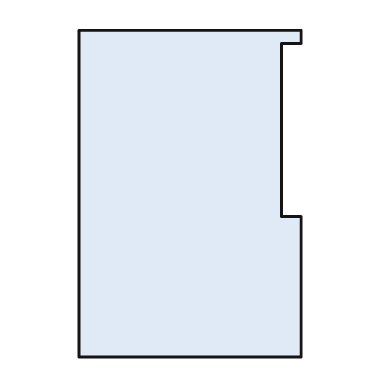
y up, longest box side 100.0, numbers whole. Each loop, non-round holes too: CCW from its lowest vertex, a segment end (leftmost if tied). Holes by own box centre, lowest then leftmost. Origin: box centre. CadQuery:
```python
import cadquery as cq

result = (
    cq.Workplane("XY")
    .moveTo(-34.0, -50.0)
    .lineTo(34.0, -50.0)
    .lineTo(34.0, -7.0)
    .lineTo(28.0, -7.0)
    .lineTo(28.0, 46.0)
    .lineTo(34.0, 46.0)
    .lineTo(34.0, 50.0)
    .lineTo(-34.0, 50.0)
    .close()
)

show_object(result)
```